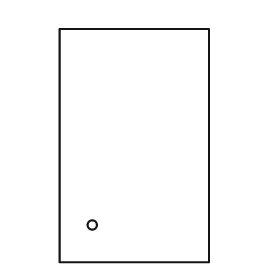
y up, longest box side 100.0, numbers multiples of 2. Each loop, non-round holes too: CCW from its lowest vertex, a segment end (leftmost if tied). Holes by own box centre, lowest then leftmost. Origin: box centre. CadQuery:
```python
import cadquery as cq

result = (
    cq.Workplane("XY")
    .moveTo(-32.0, -50.0)
    .lineTo(32.0, -50.0)
    .lineTo(32.0, 50.0)
    .lineTo(-32.0, 50.0)
    .close()
    .moveTo(-18.0, -34.0)
    .circle(2.0)
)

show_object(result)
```